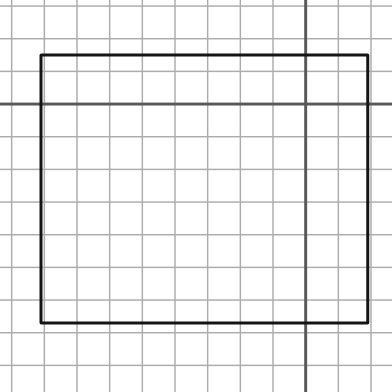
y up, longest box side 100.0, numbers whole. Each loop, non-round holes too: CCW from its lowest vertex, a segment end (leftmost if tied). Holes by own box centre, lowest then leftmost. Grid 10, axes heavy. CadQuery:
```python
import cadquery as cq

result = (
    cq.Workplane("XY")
    .moveTo(-81.0, -67.0)
    .lineTo(19.0, -67.0)
    .lineTo(19.0, 15.0)
    .lineTo(-81.0, 15.0)
    .close()
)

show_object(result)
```